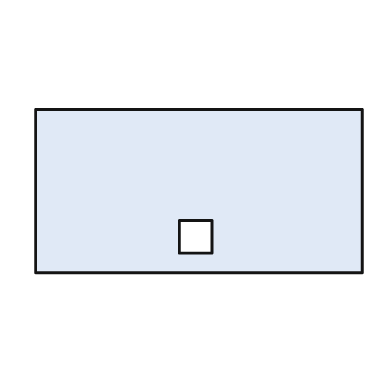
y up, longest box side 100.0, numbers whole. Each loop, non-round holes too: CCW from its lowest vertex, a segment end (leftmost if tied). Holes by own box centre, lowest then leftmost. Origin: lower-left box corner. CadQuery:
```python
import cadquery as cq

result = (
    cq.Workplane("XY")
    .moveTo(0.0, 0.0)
    .lineTo(100.0, 0.0)
    .lineTo(100.0, 50.0)
    .lineTo(0.0, 50.0)
    .close()
    .moveTo(44.0, 6.0)
    .lineTo(54.0, 6.0)
    .lineTo(54.0, 16.0)
    .lineTo(44.0, 16.0)
    .close()
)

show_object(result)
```